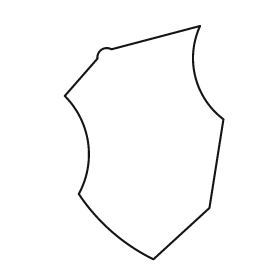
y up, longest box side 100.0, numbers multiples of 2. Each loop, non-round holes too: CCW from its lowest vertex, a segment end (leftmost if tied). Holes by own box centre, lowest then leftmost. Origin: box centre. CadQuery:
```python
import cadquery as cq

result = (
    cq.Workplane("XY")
    .moveTo(4.0, -50.0)
    .lineTo(28.0, -28.0)
    .lineTo(34.0, 10.0)
    .threePointArc((22.0, 28.0), (24.0, 50.0))
    .lineTo(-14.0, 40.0)
    .threePointArc((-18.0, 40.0), (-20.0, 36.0))
    .lineTo(-34.0, 20.0)
    .threePointArc((-24.0, 0.0), (-28.0, -22.0))
    .threePointArc((-14.0, -38.0), (4.0, -50.0))
    .close()
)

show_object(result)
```